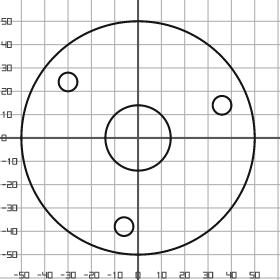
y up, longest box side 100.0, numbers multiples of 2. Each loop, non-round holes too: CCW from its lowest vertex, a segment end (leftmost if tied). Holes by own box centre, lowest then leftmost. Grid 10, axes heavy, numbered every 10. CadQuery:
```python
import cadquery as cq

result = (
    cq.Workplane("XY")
    .moveTo(0.0, 0.0)
    .circle(50.0)
    .moveTo(-6.0, -38.0)
    .circle(4.0)
    .moveTo(0.0, 0.0)
    .circle(14.0)
    .moveTo(36.0, 14.0)
    .circle(4.0)
    .moveTo(-30.0, 24.0)
    .circle(4.0)
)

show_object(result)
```